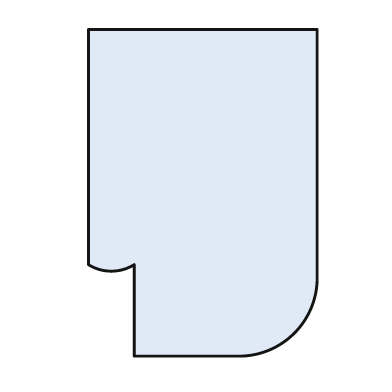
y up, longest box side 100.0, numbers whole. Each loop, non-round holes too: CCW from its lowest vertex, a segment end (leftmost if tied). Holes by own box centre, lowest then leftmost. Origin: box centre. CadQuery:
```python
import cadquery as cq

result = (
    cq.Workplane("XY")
    .moveTo(-21.0, -50.0)
    .lineTo(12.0, -50.0)
    .threePointArc((28.0, -43.0), (35.0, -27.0))
    .lineTo(35.0, 50.0)
    .lineTo(-35.0, 50.0)
    .lineTo(-35.0, -22.0)
    .threePointArc((-28.0, -24.0), (-21.0, -22.0))
    .close()
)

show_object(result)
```